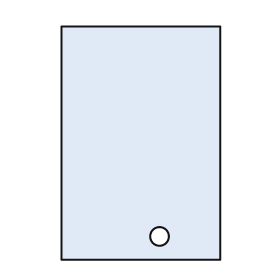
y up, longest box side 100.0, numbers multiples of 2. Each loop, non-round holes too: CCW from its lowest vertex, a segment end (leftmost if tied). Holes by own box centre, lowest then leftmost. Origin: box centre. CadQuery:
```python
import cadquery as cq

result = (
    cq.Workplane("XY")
    .moveTo(-34.0, -50.0)
    .lineTo(34.0, -50.0)
    .lineTo(34.0, 50.0)
    .lineTo(-34.0, 50.0)
    .close()
    .moveTo(8.0, -40.0)
    .circle(4.0)
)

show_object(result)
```